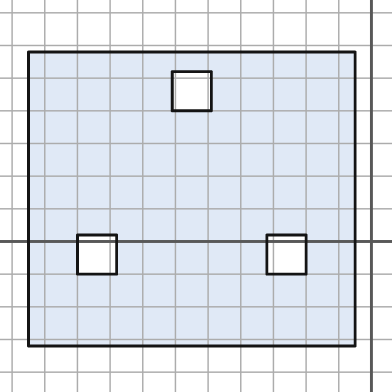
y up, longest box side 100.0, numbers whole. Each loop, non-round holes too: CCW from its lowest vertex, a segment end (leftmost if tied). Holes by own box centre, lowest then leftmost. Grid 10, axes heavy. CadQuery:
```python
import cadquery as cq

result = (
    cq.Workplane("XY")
    .moveTo(-105.0, -32.0)
    .lineTo(-5.0, -32.0)
    .lineTo(-5.0, 58.0)
    .lineTo(-105.0, 58.0)
    .close()
    .moveTo(-90.0, -10.0)
    .lineTo(-78.0, -10.0)
    .lineTo(-78.0, 2.0)
    .lineTo(-90.0, 2.0)
    .close()
    .moveTo(-32.0, -10.0)
    .lineTo(-20.0, -10.0)
    .lineTo(-20.0, 2.0)
    .lineTo(-32.0, 2.0)
    .close()
    .moveTo(-61.0, 40.0)
    .lineTo(-49.0, 40.0)
    .lineTo(-49.0, 52.0)
    .lineTo(-61.0, 52.0)
    .close()
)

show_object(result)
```